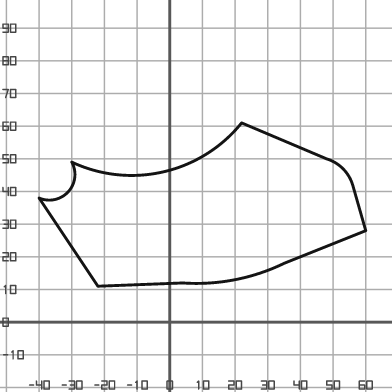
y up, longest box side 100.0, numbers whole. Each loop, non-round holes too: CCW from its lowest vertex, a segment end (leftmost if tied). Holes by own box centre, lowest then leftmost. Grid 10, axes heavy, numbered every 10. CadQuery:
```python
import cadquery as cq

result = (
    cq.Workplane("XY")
    .moveTo(-22.0, 11.0)
    .lineTo(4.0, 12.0)
    .threePointArc((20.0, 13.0), (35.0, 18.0))
    .lineTo(60.0, 28.0)
    .lineTo(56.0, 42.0)
    .threePointArc((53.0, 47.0), (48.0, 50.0))
    .lineTo(22.0, 61.0)
    .threePointArc((-2.0, 46.0), (-30.0, 49.0))
    .threePointArc((-31.0, 40.0), (-40.0, 38.0))
    .close()
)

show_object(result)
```